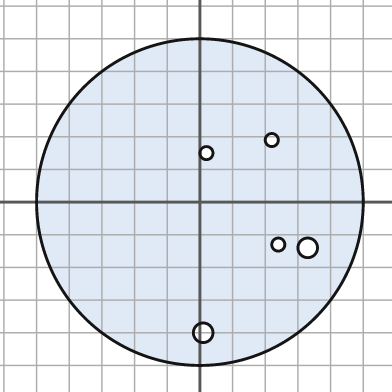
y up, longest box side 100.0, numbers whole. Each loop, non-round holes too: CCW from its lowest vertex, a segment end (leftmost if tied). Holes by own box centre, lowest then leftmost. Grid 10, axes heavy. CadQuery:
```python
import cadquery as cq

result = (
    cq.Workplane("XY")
    .moveTo(0.0, 0.0)
    .circle(50.0)
    .moveTo(1.0, -40.0)
    .circle(3.0)
    .moveTo(33.0, -14.0)
    .circle(3.0)
    .moveTo(24.0, -13.0)
    .circle(2.0)
    .moveTo(2.0, 15.0)
    .circle(2.0)
    .moveTo(22.0, 19.0)
    .circle(2.0)
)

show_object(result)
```